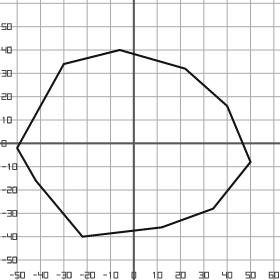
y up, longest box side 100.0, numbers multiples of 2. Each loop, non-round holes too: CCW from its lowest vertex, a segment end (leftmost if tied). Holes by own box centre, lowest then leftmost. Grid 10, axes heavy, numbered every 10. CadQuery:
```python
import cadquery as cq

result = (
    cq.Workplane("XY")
    .moveTo(-22.0, -40.0)
    .lineTo(12.0, -36.0)
    .lineTo(34.0, -28.0)
    .lineTo(50.0, -8.0)
    .lineTo(40.0, 16.0)
    .lineTo(22.0, 32.0)
    .lineTo(-6.0, 40.0)
    .lineTo(-30.0, 34.0)
    .lineTo(-50.0, -2.0)
    .lineTo(-42.0, -16.0)
    .close()
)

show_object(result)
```